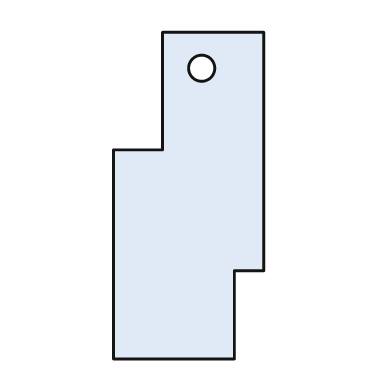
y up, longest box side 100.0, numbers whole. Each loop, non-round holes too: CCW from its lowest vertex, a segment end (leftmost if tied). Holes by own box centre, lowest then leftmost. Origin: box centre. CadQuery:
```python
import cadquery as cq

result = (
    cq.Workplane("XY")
    .moveTo(-23.0, -50.0)
    .lineTo(14.0, -50.0)
    .lineTo(14.0, -23.0)
    .lineTo(23.0, -23.0)
    .lineTo(23.0, 50.0)
    .lineTo(-8.0, 50.0)
    .lineTo(-8.0, 14.0)
    .lineTo(-23.0, 14.0)
    .close()
    .moveTo(4.0, 39.0)
    .circle(4.0)
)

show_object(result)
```